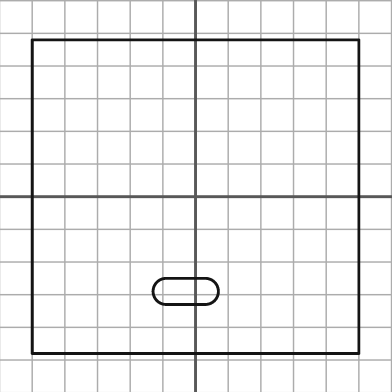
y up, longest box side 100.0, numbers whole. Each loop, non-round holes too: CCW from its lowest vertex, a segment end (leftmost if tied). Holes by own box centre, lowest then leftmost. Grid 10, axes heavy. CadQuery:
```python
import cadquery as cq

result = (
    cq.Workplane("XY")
    .moveTo(-50.0, -48.0)
    .lineTo(50.0, -48.0)
    .lineTo(50.0, 48.0)
    .lineTo(-50.0, 48.0)
    .close()
    .moveTo(-9.0, -33.0)
    .lineTo(3.0, -33.0)
    .threePointArc((7.0, -29.0), (3.0, -25.0))
    .lineTo(-9.0, -25.0)
    .threePointArc((-13.0, -29.0), (-9.0, -33.0))
    .close()
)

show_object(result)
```